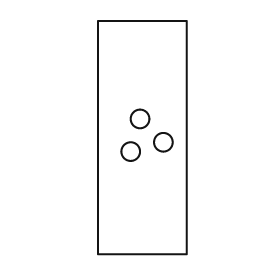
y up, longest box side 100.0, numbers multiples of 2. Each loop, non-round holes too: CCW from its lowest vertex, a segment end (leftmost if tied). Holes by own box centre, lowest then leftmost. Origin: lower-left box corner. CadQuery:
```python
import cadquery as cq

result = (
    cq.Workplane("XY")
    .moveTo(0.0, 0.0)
    .lineTo(38.0, 0.0)
    .lineTo(38.0, 100.0)
    .lineTo(0.0, 100.0)
    .close()
    .moveTo(14.0, 44.0)
    .circle(4.0)
    .moveTo(28.0, 48.0)
    .circle(4.0)
    .moveTo(18.0, 58.0)
    .circle(4.0)
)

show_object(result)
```